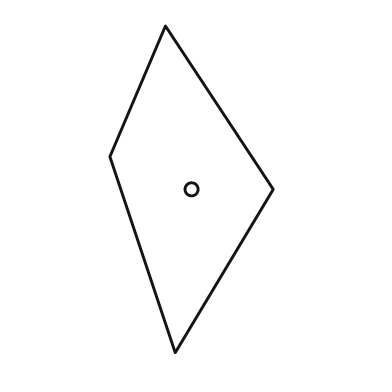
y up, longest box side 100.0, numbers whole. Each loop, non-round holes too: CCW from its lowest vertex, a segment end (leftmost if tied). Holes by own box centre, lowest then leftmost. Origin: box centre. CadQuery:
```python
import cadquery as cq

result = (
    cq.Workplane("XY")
    .moveTo(-5.0, -50.0)
    .lineTo(25.0, 0.0)
    .lineTo(-8.0, 50.0)
    .lineTo(-25.0, 10.0)
    .close()
    .moveTo(0.0, 0.0)
    .circle(2.0)
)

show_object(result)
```